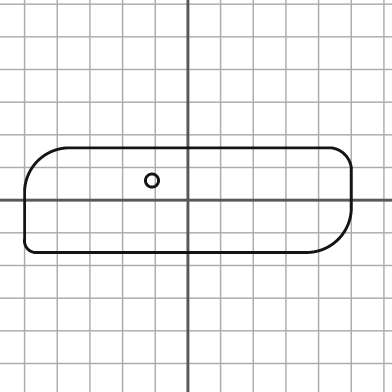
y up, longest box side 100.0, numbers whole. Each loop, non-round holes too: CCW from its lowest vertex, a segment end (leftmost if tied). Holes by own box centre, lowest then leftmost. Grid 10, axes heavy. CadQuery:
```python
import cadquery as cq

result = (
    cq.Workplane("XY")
    .moveTo(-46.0, -16.0)
    .lineTo(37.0, -16.0)
    .threePointArc((46.0, -12.0), (50.0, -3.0))
    .lineTo(50.0, 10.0)
    .threePointArc((48.0, 14.0), (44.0, 16.0))
    .lineTo(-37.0, 16.0)
    .threePointArc((-46.0, 12.0), (-50.0, 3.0))
    .lineTo(-50.0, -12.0)
    .threePointArc((-49.0, -15.0), (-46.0, -16.0))
    .close()
    .moveTo(-11.0, 6.0)
    .circle(2.0)
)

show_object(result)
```